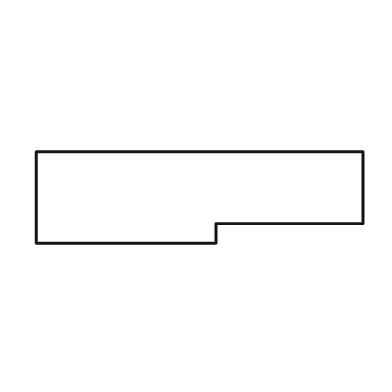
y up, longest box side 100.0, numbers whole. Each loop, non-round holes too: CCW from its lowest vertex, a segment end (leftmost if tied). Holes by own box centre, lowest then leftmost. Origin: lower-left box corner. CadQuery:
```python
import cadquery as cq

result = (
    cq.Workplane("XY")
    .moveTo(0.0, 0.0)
    .lineTo(55.0, 0.0)
    .lineTo(55.0, 6.0)
    .lineTo(100.0, 6.0)
    .lineTo(100.0, 28.0)
    .lineTo(0.0, 28.0)
    .close()
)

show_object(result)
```